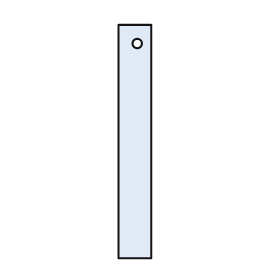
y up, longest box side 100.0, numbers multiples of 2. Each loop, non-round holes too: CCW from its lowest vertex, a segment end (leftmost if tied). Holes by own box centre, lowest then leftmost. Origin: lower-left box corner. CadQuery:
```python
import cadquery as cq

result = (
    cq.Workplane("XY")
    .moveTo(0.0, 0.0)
    .lineTo(14.0, 0.0)
    .lineTo(14.0, 100.0)
    .lineTo(0.0, 100.0)
    .close()
    .moveTo(8.0, 92.0)
    .circle(2.0)
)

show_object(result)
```